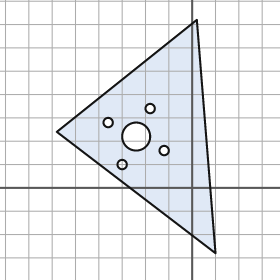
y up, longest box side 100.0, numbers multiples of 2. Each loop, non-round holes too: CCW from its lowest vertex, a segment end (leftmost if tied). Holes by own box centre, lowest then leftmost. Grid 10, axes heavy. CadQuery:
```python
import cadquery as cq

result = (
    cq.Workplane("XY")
    .moveTo(10.0, -28.0)
    .lineTo(2.0, 72.0)
    .lineTo(-58.0, 24.0)
    .close()
    .moveTo(-30.0, 10.0)
    .circle(2.0)
    .moveTo(-12.0, 16.0)
    .circle(2.0)
    .moveTo(-24.0, 22.0)
    .circle(6.0)
    .moveTo(-36.0, 28.0)
    .circle(2.0)
    .moveTo(-18.0, 34.0)
    .circle(2.0)
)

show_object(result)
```